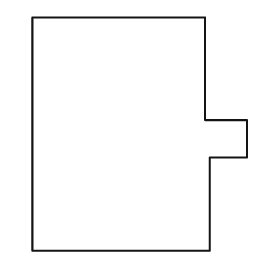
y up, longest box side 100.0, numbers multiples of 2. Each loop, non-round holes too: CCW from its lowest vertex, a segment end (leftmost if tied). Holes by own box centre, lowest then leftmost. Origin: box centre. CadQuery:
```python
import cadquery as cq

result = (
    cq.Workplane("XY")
    .moveTo(-46.0, -50.0)
    .lineTo(30.0, -50.0)
    .lineTo(30.0, -10.0)
    .lineTo(46.0, -10.0)
    .lineTo(46.0, 6.0)
    .lineTo(28.0, 6.0)
    .lineTo(28.0, 50.0)
    .lineTo(-46.0, 50.0)
    .close()
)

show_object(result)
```